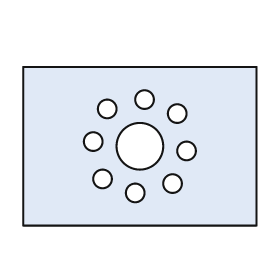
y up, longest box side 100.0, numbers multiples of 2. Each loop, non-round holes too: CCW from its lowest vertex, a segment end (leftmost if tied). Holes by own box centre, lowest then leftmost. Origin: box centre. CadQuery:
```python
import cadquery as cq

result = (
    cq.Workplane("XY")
    .moveTo(-50.0, -34.0)
    .lineTo(50.0, -34.0)
    .lineTo(50.0, 34.0)
    .lineTo(-50.0, 34.0)
    .close()
    .moveTo(-2.0, -20.0)
    .circle(4.0)
    .moveTo(14.0, -16.0)
    .circle(4.0)
    .moveTo(-16.0, -14.0)
    .circle(4.0)
    .moveTo(20.0, -2.0)
    .circle(4.0)
    .moveTo(0.0, 0.0)
    .circle(10.0)
    .moveTo(-20.0, 2.0)
    .circle(4.0)
    .moveTo(16.0, 14.0)
    .circle(4.0)
    .moveTo(-14.0, 16.0)
    .circle(4.0)
    .moveTo(2.0, 20.0)
    .circle(4.0)
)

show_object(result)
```